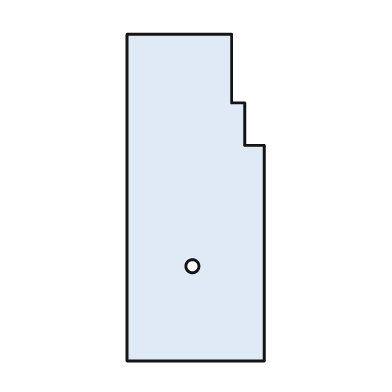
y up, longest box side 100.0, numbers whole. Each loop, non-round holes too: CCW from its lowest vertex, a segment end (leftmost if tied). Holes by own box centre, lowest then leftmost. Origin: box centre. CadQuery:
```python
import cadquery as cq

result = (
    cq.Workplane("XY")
    .moveTo(-21.0, -50.0)
    .lineTo(21.0, -50.0)
    .lineTo(21.0, 16.0)
    .lineTo(15.0, 16.0)
    .lineTo(15.0, 29.0)
    .lineTo(11.0, 29.0)
    .lineTo(11.0, 50.0)
    .lineTo(-21.0, 50.0)
    .close()
    .moveTo(-1.0, -21.0)
    .circle(2.0)
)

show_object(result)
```